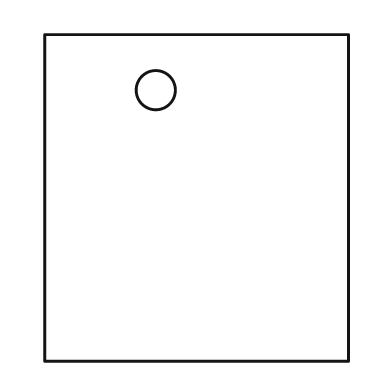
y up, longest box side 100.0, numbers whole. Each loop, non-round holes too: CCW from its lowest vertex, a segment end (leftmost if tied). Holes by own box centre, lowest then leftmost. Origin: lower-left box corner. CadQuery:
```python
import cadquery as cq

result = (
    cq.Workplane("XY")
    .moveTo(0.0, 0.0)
    .lineTo(93.0, 0.0)
    .lineTo(93.0, 100.0)
    .lineTo(0.0, 100.0)
    .close()
    .moveTo(34.0, 83.0)
    .circle(6.0)
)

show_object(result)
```